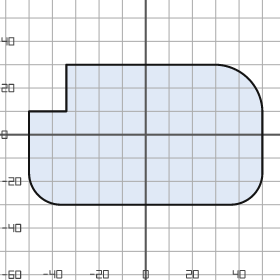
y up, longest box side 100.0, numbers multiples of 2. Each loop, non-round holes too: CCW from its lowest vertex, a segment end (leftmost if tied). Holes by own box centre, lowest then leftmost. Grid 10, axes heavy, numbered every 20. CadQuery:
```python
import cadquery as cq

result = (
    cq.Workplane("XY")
    .moveTo(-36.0, -30.0)
    .lineTo(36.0, -30.0)
    .threePointArc((46.0, -26.0), (50.0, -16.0))
    .lineTo(50.0, 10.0)
    .threePointArc((44.0, 24.0), (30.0, 30.0))
    .lineTo(-34.0, 30.0)
    .lineTo(-34.0, 10.0)
    .lineTo(-50.0, 10.0)
    .lineTo(-50.0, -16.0)
    .threePointArc((-46.0, -26.0), (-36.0, -30.0))
    .close()
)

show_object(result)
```